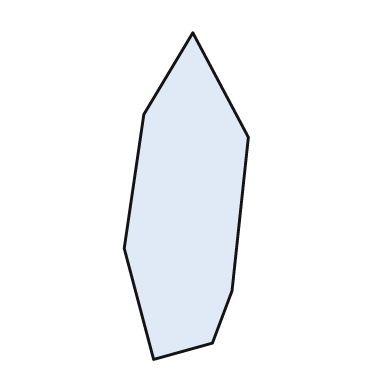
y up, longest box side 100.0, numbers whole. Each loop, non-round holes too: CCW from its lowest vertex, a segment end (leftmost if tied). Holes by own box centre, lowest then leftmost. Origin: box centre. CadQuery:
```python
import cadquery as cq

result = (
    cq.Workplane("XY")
    .moveTo(-10.0, -50.0)
    .lineTo(8.0, -45.0)
    .lineTo(14.0, -29.0)
    .lineTo(19.0, 18.0)
    .lineTo(2.0, 50.0)
    .lineTo(-13.0, 25.0)
    .lineTo(-19.0, -16.0)
    .close()
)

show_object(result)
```